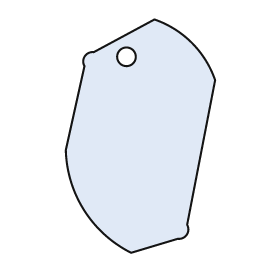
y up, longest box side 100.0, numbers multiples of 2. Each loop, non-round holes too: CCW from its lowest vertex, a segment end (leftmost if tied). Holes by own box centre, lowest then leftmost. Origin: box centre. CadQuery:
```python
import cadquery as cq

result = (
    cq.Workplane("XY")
    .moveTo(-4.0, -50.0)
    .lineTo(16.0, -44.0)
    .threePointArc((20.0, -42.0), (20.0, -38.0))
    .lineTo(32.0, 24.0)
    .threePointArc((22.0, 40.0), (6.0, 50.0))
    .lineTo(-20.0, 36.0)
    .threePointArc((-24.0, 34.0), (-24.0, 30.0))
    .lineTo(-32.0, -6.0)
    .threePointArc((-24.0, -32.0), (-4.0, -50.0))
    .close()
    .moveTo(-6.0, 34.0)
    .circle(4.0)
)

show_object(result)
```